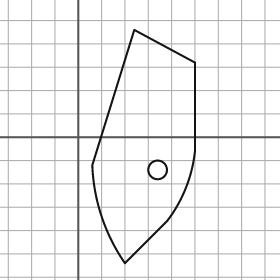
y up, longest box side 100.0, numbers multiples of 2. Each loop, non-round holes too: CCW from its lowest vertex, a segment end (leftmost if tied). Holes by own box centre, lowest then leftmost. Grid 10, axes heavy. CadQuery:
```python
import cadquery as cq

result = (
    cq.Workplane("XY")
    .moveTo(20.0, -54.0)
    .lineTo(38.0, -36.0)
    .threePointArc((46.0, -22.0), (50.0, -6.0))
    .lineTo(50.0, 32.0)
    .lineTo(24.0, 46.0)
    .lineTo(6.0, -12.0)
    .threePointArc((10.0, -34.0), (20.0, -54.0))
    .close()
    .moveTo(34.0, -14.0)
    .circle(4.0)
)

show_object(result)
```